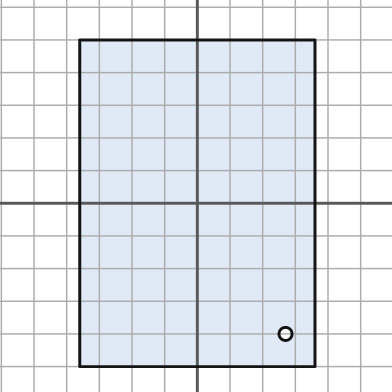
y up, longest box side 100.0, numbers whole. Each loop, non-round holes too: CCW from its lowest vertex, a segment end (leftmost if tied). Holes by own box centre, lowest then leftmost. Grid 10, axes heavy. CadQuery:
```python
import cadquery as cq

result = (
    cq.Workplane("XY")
    .moveTo(-36.0, -50.0)
    .lineTo(36.0, -50.0)
    .lineTo(36.0, 50.0)
    .lineTo(-36.0, 50.0)
    .close()
    .moveTo(27.0, -40.0)
    .circle(2.0)
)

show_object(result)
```